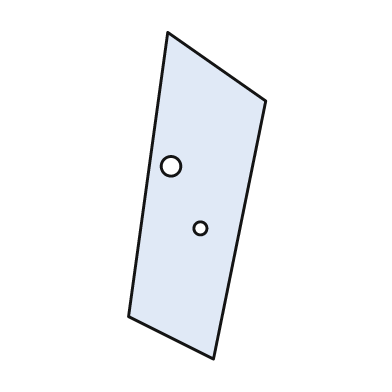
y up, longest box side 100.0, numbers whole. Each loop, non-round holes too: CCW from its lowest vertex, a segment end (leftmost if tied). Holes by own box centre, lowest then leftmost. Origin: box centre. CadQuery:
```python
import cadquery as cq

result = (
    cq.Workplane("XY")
    .moveTo(5.0, -50.0)
    .lineTo(21.0, 29.0)
    .lineTo(-9.0, 50.0)
    .lineTo(-21.0, -37.0)
    .close()
    .moveTo(1.0, -10.0)
    .circle(2.0)
    .moveTo(-8.0, 9.0)
    .circle(3.0)
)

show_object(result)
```